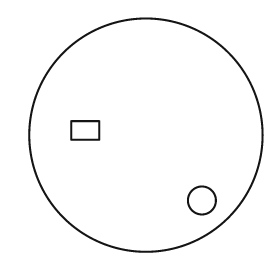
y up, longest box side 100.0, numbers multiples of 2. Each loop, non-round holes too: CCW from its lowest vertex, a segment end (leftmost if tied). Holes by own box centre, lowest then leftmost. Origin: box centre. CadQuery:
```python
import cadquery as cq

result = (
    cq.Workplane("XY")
    .moveTo(0.0, 0.0)
    .circle(50.0)
    .moveTo(24.0, -28.0)
    .circle(6.0)
    .moveTo(-32.0, -2.0)
    .lineTo(-20.0, -2.0)
    .lineTo(-20.0, 6.0)
    .lineTo(-32.0, 6.0)
    .close()
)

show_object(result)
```